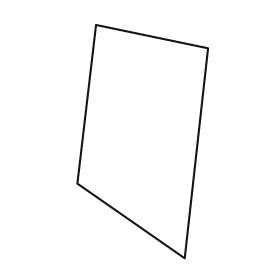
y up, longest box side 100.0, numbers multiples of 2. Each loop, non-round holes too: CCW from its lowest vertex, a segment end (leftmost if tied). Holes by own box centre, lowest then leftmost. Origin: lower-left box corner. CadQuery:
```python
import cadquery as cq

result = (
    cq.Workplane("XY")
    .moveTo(46.0, 0.0)
    .lineTo(56.0, 90.0)
    .lineTo(8.0, 100.0)
    .lineTo(0.0, 32.0)
    .close()
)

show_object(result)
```